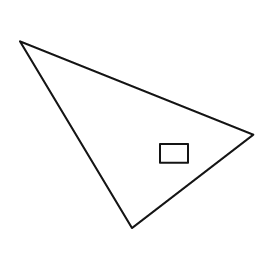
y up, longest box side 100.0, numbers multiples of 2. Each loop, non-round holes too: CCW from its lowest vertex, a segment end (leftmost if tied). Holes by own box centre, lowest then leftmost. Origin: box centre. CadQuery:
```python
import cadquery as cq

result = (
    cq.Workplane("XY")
    .moveTo(-2.0, -40.0)
    .lineTo(50.0, 0.0)
    .lineTo(-50.0, 40.0)
    .close()
    .moveTo(10.0, -12.0)
    .lineTo(22.0, -12.0)
    .lineTo(22.0, -4.0)
    .lineTo(10.0, -4.0)
    .close()
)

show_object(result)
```